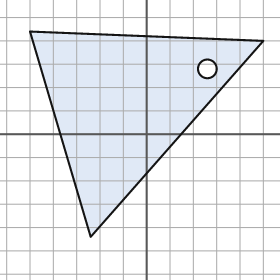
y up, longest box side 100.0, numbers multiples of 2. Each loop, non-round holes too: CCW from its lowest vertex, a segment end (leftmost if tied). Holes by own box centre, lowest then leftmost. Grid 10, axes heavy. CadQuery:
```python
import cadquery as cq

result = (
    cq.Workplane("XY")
    .moveTo(-24.0, -44.0)
    .lineTo(50.0, 40.0)
    .lineTo(-50.0, 44.0)
    .close()
    .moveTo(26.0, 28.0)
    .circle(4.0)
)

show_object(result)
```